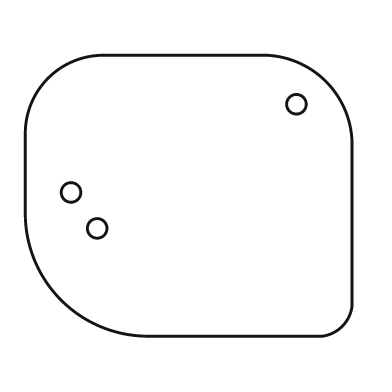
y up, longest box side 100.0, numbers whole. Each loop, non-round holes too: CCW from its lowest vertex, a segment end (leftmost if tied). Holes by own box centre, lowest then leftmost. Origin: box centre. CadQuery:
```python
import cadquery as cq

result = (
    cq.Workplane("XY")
    .moveTo(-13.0, -43.0)
    .lineTo(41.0, -43.0)
    .threePointArc((47.0, -40.0), (50.0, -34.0))
    .lineTo(50.0, 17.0)
    .threePointArc((42.0, 35.0), (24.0, 43.0))
    .lineTo(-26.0, 43.0)
    .threePointArc((-43.0, 36.0), (-50.0, 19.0))
    .lineTo(-50.0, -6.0)
    .threePointArc((-39.0, -32.0), (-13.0, -43.0))
    .close()
    .moveTo(-28.0, -10.0)
    .circle(3.0)
    .moveTo(-36.0, 1.0)
    .circle(3.0)
    .moveTo(33.0, 28.0)
    .circle(3.0)
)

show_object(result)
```